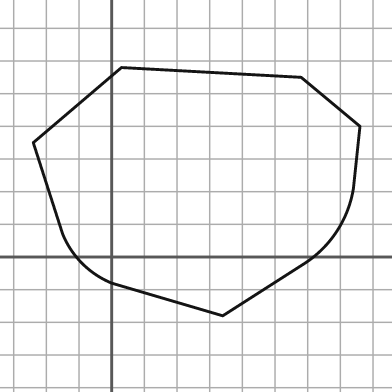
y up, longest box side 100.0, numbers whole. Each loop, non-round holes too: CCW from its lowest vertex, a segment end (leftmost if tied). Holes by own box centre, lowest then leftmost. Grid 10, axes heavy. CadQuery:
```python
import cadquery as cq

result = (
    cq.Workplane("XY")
    .moveTo(34.0, -18.0)
    .lineTo(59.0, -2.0)
    .threePointArc((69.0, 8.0), (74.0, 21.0))
    .lineTo(76.0, 40.0)
    .lineTo(58.0, 55.0)
    .lineTo(3.0, 58.0)
    .lineTo(-24.0, 35.0)
    .lineTo(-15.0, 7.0)
    .threePointArc((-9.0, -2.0), (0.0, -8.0))
    .close()
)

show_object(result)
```